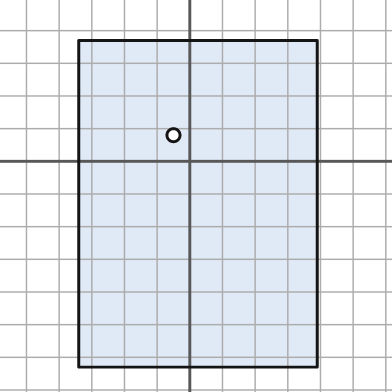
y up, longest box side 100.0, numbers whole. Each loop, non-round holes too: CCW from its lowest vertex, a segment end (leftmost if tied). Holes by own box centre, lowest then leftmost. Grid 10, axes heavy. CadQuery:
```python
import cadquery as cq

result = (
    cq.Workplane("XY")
    .moveTo(-34.0, -63.0)
    .lineTo(39.0, -63.0)
    .lineTo(39.0, 37.0)
    .lineTo(-34.0, 37.0)
    .close()
    .moveTo(-5.0, 8.0)
    .circle(2.0)
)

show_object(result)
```